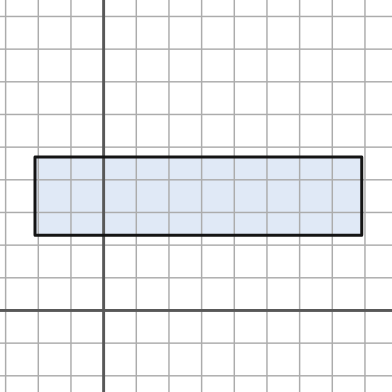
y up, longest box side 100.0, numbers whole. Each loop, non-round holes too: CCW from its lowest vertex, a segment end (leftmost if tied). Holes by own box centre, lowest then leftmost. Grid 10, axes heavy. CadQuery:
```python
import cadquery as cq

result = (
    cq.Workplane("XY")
    .moveTo(-21.0, 23.0)
    .lineTo(79.0, 23.0)
    .lineTo(79.0, 47.0)
    .lineTo(-21.0, 47.0)
    .close()
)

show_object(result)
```